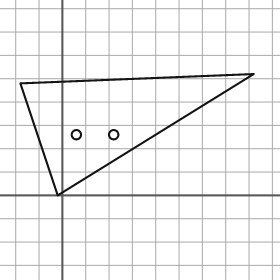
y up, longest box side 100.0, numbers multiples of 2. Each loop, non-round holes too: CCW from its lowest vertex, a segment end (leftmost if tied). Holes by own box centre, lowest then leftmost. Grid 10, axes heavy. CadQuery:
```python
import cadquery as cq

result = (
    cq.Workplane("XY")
    .moveTo(-2.0, 0.0)
    .lineTo(82.0, 52.0)
    .lineTo(-18.0, 48.0)
    .close()
    .moveTo(6.0, 26.0)
    .circle(2.0)
    .moveTo(22.0, 26.0)
    .circle(2.0)
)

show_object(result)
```